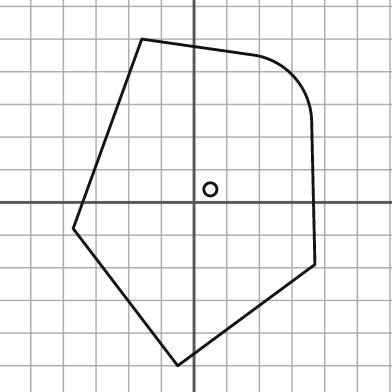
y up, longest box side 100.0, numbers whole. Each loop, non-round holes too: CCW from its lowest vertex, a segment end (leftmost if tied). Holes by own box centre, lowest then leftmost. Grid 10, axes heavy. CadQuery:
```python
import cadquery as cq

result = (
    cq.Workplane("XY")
    .moveTo(-5.0, -50.0)
    .lineTo(37.0, -19.0)
    .lineTo(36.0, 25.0)
    .threePointArc((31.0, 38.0), (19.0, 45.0))
    .lineTo(-16.0, 50.0)
    .lineTo(-37.0, -8.0)
    .close()
    .moveTo(5.0, 4.0)
    .circle(2.0)
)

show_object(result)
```